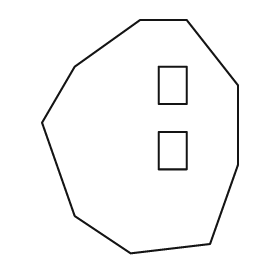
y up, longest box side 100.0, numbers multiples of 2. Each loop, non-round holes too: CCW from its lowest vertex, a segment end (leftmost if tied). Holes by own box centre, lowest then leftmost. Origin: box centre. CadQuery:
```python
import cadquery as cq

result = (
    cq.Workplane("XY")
    .moveTo(-4.0, -50.0)
    .lineTo(30.0, -46.0)
    .lineTo(42.0, -12.0)
    .lineTo(42.0, 22.0)
    .lineTo(20.0, 50.0)
    .lineTo(0.0, 50.0)
    .lineTo(-28.0, 30.0)
    .lineTo(-42.0, 6.0)
    .lineTo(-28.0, -34.0)
    .close()
    .moveTo(8.0, -14.0)
    .lineTo(20.0, -14.0)
    .lineTo(20.0, 2.0)
    .lineTo(8.0, 2.0)
    .close()
    .moveTo(8.0, 14.0)
    .lineTo(20.0, 14.0)
    .lineTo(20.0, 30.0)
    .lineTo(8.0, 30.0)
    .close()
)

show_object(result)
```